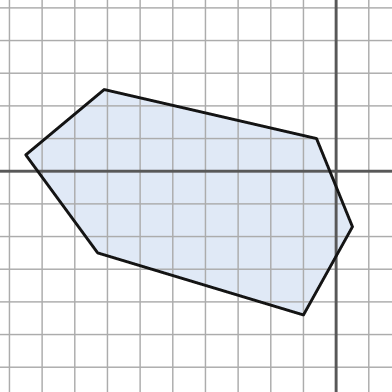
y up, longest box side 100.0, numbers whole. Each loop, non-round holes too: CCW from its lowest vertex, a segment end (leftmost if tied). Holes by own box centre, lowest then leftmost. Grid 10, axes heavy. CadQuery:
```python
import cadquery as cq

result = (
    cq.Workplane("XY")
    .moveTo(-10.0, -44.0)
    .lineTo(5.0, -17.0)
    .lineTo(-6.0, 10.0)
    .lineTo(-71.0, 25.0)
    .lineTo(-95.0, 5.0)
    .lineTo(-73.0, -25.0)
    .close()
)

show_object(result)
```